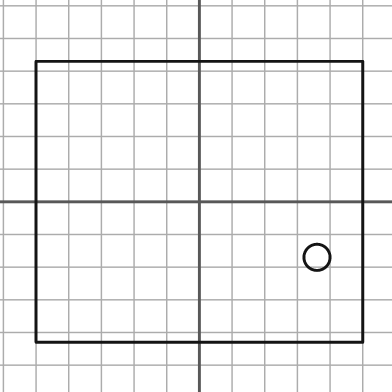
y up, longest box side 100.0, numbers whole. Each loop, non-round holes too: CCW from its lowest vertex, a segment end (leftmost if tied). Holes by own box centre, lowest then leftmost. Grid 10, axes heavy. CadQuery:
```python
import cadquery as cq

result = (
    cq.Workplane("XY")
    .moveTo(-50.0, -43.0)
    .lineTo(50.0, -43.0)
    .lineTo(50.0, 43.0)
    .lineTo(-50.0, 43.0)
    .close()
    .moveTo(36.0, -17.0)
    .circle(4.0)
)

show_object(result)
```